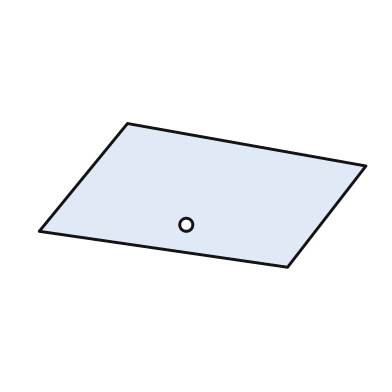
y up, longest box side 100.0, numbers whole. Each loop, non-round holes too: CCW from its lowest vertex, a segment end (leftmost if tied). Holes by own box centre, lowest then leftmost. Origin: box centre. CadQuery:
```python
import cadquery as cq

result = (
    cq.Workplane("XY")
    .moveTo(26.0, -22.0)
    .lineTo(50.0, 9.0)
    .lineTo(-23.0, 22.0)
    .lineTo(-50.0, -11.0)
    .close()
    .moveTo(-5.0, -9.0)
    .circle(2.0)
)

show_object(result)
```